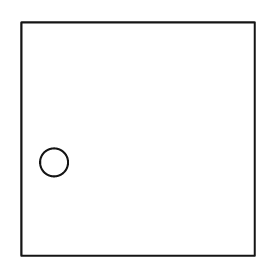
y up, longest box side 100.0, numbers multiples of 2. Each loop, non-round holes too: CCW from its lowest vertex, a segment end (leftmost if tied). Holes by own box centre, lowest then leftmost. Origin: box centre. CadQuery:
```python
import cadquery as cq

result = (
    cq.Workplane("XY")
    .moveTo(-50.0, -50.0)
    .lineTo(50.0, -50.0)
    .lineTo(50.0, 50.0)
    .lineTo(-50.0, 50.0)
    .close()
    .moveTo(-36.0, -10.0)
    .circle(6.0)
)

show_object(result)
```